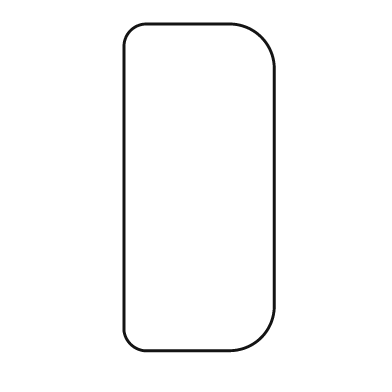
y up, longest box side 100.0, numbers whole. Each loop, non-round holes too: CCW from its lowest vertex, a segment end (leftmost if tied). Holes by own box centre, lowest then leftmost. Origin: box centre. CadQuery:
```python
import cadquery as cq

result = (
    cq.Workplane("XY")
    .moveTo(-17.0, -50.0)
    .lineTo(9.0, -50.0)
    .threePointArc((19.0, -46.0), (23.0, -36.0))
    .lineTo(23.0, 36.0)
    .threePointArc((19.0, 46.0), (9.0, 50.0))
    .lineTo(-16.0, 50.0)
    .threePointArc((-21.0, 48.0), (-23.0, 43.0))
    .lineTo(-23.0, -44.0)
    .threePointArc((-21.0, -48.0), (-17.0, -50.0))
    .close()
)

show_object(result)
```